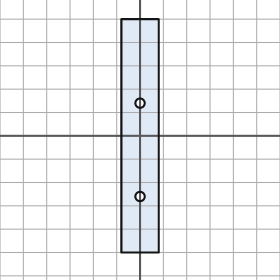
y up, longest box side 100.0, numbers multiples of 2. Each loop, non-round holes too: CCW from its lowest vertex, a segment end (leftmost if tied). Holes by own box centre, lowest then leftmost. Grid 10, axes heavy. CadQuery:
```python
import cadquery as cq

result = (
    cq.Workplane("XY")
    .moveTo(-8.0, -50.0)
    .lineTo(8.0, -50.0)
    .lineTo(8.0, 50.0)
    .lineTo(-8.0, 50.0)
    .close()
    .moveTo(0.0, -26.0)
    .circle(2.0)
    .moveTo(0.0, 14.0)
    .circle(2.0)
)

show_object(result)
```